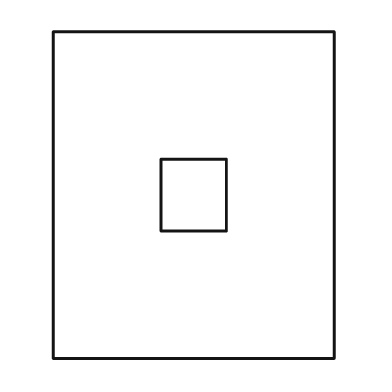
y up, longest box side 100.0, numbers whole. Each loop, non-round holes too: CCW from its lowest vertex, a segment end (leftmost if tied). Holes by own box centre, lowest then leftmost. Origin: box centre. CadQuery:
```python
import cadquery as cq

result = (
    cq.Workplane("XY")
    .moveTo(-43.0, -50.0)
    .lineTo(43.0, -50.0)
    .lineTo(43.0, 50.0)
    .lineTo(-43.0, 50.0)
    .close()
    .moveTo(-10.0, -11.0)
    .lineTo(10.0, -11.0)
    .lineTo(10.0, 11.0)
    .lineTo(-10.0, 11.0)
    .close()
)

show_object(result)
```